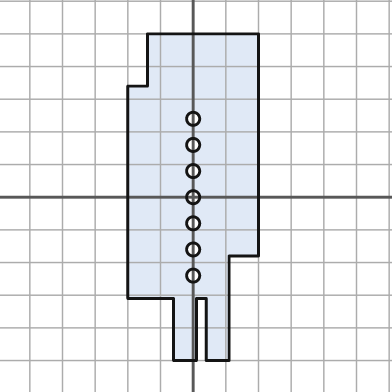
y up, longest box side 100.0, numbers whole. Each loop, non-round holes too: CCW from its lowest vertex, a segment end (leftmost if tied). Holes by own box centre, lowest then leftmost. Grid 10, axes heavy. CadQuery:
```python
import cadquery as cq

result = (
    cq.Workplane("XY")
    .moveTo(-6.0, -50.0)
    .lineTo(1.0, -50.0)
    .lineTo(1.0, -31.0)
    .lineTo(4.0, -31.0)
    .lineTo(4.0, -50.0)
    .lineTo(11.0, -50.0)
    .lineTo(11.0, -18.0)
    .lineTo(20.0, -18.0)
    .lineTo(20.0, 50.0)
    .lineTo(-14.0, 50.0)
    .lineTo(-14.0, 34.0)
    .lineTo(-20.0, 34.0)
    .lineTo(-20.0, -31.0)
    .lineTo(-6.0, -31.0)
    .close()
    .moveTo(0.0, -24.0)
    .circle(2.0)
    .moveTo(0.0, -16.0)
    .circle(2.0)
    .moveTo(0.0, -8.0)
    .circle(2.0)
    .moveTo(0.0, 0.0)
    .circle(2.0)
    .moveTo(0.0, 8.0)
    .circle(2.0)
    .moveTo(0.0, 16.0)
    .circle(2.0)
    .moveTo(0.0, 24.0)
    .circle(2.0)
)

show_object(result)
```